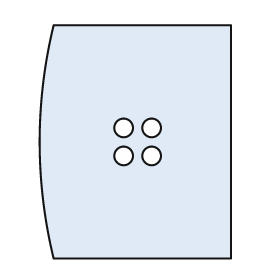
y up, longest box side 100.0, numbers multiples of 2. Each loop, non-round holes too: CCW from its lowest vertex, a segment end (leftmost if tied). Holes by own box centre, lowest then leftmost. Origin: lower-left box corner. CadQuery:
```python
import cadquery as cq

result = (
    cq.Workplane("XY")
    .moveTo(6.0, 0.0)
    .lineTo(82.0, 0.0)
    .lineTo(82.0, 100.0)
    .lineTo(6.0, 100.0)
    .threePointArc((0.0, 50.0), (6.0, 0.0))
    .close()
    .moveTo(36.0, 44.0)
    .circle(4.0)
    .moveTo(48.0, 44.0)
    .circle(4.0)
    .moveTo(36.0, 56.0)
    .circle(4.0)
    .moveTo(48.0, 56.0)
    .circle(4.0)
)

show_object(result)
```